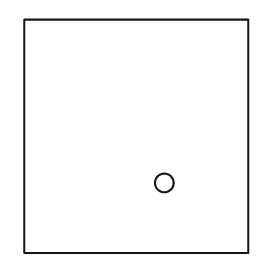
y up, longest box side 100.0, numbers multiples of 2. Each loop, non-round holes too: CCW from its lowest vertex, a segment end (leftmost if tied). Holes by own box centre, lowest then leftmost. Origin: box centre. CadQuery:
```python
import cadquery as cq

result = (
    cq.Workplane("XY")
    .moveTo(-48.0, -50.0)
    .lineTo(48.0, -50.0)
    .lineTo(48.0, 50.0)
    .lineTo(-48.0, 50.0)
    .close()
    .moveTo(12.0, -20.0)
    .circle(4.0)
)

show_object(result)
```